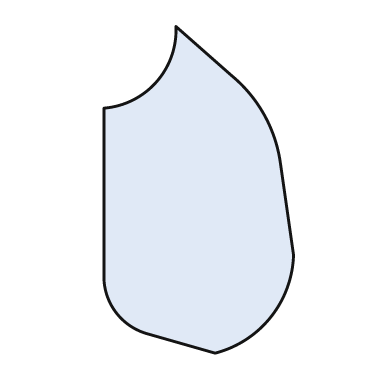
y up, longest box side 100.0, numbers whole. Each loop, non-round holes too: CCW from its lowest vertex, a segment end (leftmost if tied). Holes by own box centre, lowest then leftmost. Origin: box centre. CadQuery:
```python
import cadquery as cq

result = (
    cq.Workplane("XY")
    .moveTo(5.0, -50.0)
    .threePointArc((22.0, -39.0), (29.0, -20.0))
    .lineTo(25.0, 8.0)
    .threePointArc((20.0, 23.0), (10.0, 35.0))
    .lineTo(-7.0, 50.0)
    .threePointArc((-13.0, 33.0), (-29.0, 25.0))
    .lineTo(-29.0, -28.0)
    .threePointArc((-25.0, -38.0), (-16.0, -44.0))
    .close()
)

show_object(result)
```